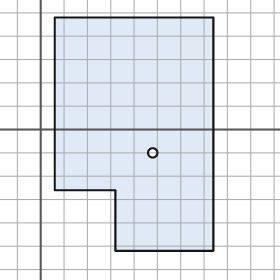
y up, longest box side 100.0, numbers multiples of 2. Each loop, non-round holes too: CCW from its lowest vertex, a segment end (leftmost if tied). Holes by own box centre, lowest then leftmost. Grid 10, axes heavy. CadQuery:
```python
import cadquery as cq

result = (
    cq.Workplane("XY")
    .moveTo(32.0, -52.0)
    .lineTo(74.0, -52.0)
    .lineTo(74.0, 48.0)
    .lineTo(6.0, 48.0)
    .lineTo(6.0, -26.0)
    .lineTo(32.0, -26.0)
    .close()
    .moveTo(48.0, -10.0)
    .circle(2.0)
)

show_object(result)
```